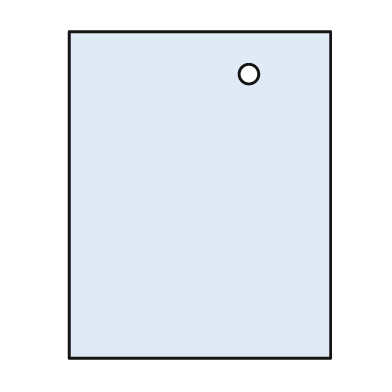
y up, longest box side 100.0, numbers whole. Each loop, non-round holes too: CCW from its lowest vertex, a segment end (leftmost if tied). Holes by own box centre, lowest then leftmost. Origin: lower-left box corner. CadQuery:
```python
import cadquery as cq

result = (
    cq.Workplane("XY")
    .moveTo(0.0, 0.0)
    .lineTo(80.0, 0.0)
    .lineTo(80.0, 100.0)
    .lineTo(0.0, 100.0)
    .close()
    .moveTo(55.0, 87.0)
    .circle(3.0)
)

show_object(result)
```